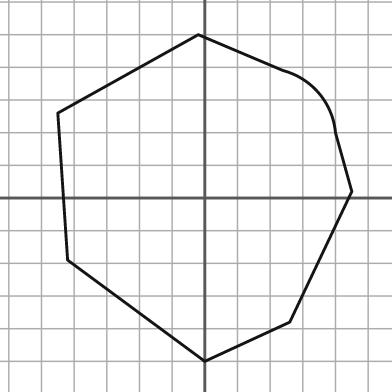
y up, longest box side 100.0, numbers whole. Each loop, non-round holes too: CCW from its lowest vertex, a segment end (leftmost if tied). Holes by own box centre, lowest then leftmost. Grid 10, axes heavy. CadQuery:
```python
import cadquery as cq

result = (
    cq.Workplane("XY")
    .moveTo(0.0, -50.0)
    .lineTo(26.0, -38.0)
    .lineTo(45.0, 2.0)
    .lineTo(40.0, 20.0)
    .threePointArc((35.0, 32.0), (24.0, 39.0))
    .lineTo(-2.0, 50.0)
    .lineTo(-45.0, 26.0)
    .lineTo(-42.0, -19.0)
    .close()
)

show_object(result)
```